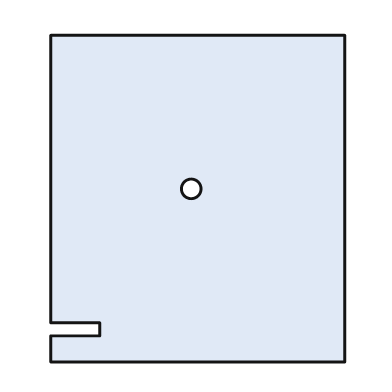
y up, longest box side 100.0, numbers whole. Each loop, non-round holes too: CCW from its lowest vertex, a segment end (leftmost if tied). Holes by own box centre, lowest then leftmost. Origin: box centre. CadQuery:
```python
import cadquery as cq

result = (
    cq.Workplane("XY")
    .moveTo(-45.0, -50.0)
    .lineTo(45.0, -50.0)
    .lineTo(45.0, 50.0)
    .lineTo(-45.0, 50.0)
    .lineTo(-45.0, -38.0)
    .lineTo(-30.0, -38.0)
    .lineTo(-30.0, -42.0)
    .lineTo(-45.0, -42.0)
    .close()
    .moveTo(-2.0, 3.0)
    .circle(3.0)
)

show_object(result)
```